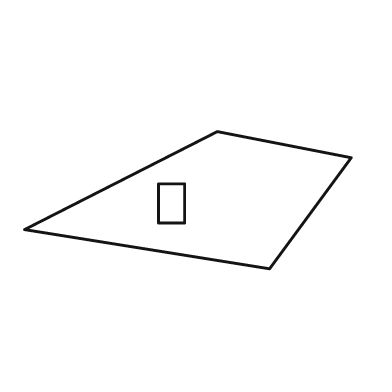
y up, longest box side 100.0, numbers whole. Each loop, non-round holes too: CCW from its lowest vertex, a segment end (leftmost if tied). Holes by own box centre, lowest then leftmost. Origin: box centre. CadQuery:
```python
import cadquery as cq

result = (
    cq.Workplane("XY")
    .moveTo(25.0, -21.0)
    .lineTo(50.0, 13.0)
    .lineTo(9.0, 21.0)
    .lineTo(-50.0, -9.0)
    .close()
    .moveTo(-9.0, -7.0)
    .lineTo(-1.0, -7.0)
    .lineTo(-1.0, 5.0)
    .lineTo(-9.0, 5.0)
    .close()
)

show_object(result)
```